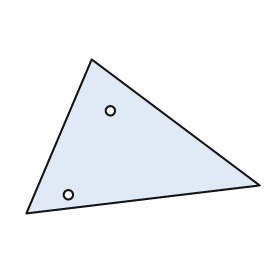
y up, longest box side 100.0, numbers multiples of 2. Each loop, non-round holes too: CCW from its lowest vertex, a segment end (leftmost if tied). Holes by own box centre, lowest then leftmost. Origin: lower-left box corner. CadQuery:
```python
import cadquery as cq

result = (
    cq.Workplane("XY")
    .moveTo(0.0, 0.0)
    .lineTo(100.0, 12.0)
    .lineTo(28.0, 66.0)
    .close()
    .moveTo(18.0, 8.0)
    .circle(2.0)
    .moveTo(36.0, 44.0)
    .circle(2.0)
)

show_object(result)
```